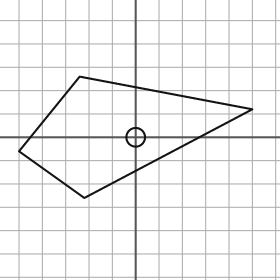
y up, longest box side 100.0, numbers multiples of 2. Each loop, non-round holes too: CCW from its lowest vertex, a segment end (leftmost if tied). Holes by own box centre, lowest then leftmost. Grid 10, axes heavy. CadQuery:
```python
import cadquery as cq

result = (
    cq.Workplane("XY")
    .moveTo(-22.0, -26.0)
    .lineTo(50.0, 12.0)
    .lineTo(-24.0, 26.0)
    .lineTo(-50.0, -6.0)
    .close()
    .moveTo(0.0, 0.0)
    .circle(4.0)
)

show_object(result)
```